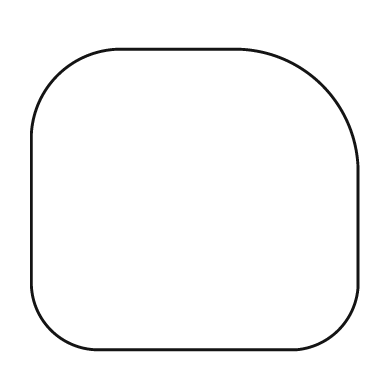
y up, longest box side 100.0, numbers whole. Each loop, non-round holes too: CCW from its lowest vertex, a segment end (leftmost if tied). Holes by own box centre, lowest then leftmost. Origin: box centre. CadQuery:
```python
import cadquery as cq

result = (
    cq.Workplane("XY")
    .moveTo(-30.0, -46.0)
    .lineTo(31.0, -46.0)
    .threePointArc((44.0, -40.0), (50.0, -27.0))
    .lineTo(50.0, 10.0)
    .threePointArc((39.0, 35.0), (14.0, 46.0))
    .lineTo(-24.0, 46.0)
    .threePointArc((-42.0, 38.0), (-50.0, 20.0))
    .lineTo(-50.0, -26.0)
    .threePointArc((-44.0, -40.0), (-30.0, -46.0))
    .close()
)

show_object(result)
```